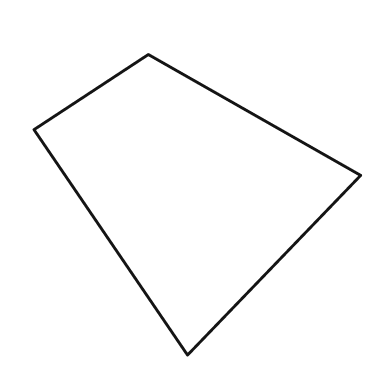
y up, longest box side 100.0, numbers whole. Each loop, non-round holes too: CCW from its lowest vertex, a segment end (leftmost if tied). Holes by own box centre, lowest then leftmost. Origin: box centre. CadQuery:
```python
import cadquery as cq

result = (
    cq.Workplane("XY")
    .moveTo(-3.0, -46.0)
    .lineTo(50.0, 9.0)
    .lineTo(-15.0, 46.0)
    .lineTo(-50.0, 23.0)
    .close()
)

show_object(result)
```